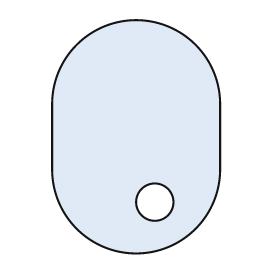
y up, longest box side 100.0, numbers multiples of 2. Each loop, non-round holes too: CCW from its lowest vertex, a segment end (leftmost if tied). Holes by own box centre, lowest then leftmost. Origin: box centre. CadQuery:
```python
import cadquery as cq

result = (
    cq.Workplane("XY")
    .moveTo(-36.0, -14.0)
    .threePointArc((0.0, -50.0), (36.0, -14.0))
    .lineTo(36.0, 14.0)
    .threePointArc((0.0, 50.0), (-36.0, 14.0))
    .close()
    .moveTo(8.0, -28.0)
    .circle(8.0)
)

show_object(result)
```